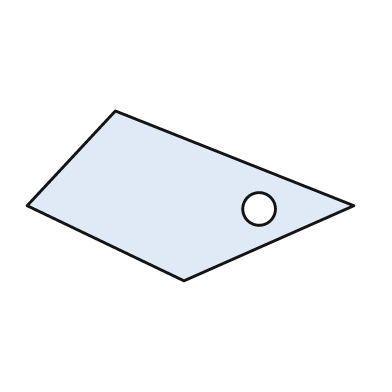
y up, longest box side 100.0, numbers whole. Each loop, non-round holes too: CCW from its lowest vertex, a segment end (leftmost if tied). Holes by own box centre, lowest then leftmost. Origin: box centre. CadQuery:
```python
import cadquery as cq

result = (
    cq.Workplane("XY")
    .moveTo(-2.0, -26.0)
    .lineTo(50.0, -3.0)
    .lineTo(-23.0, 26.0)
    .lineTo(-50.0, -3.0)
    .close()
    .moveTo(21.0, -4.0)
    .circle(5.0)
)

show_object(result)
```